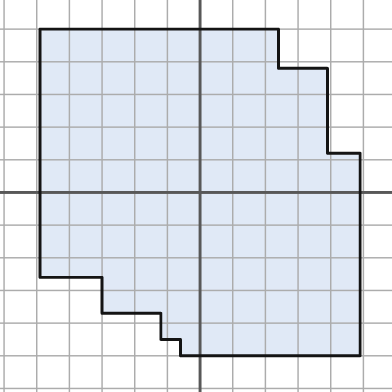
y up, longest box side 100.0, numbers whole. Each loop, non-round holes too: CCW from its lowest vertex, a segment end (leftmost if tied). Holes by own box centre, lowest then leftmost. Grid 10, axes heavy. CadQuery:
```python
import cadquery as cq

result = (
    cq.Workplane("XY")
    .moveTo(-6.0, -50.0)
    .lineTo(49.0, -50.0)
    .lineTo(49.0, 12.0)
    .lineTo(39.0, 12.0)
    .lineTo(39.0, 38.0)
    .lineTo(24.0, 38.0)
    .lineTo(24.0, 50.0)
    .lineTo(-49.0, 50.0)
    .lineTo(-49.0, -26.0)
    .lineTo(-30.0, -26.0)
    .lineTo(-30.0, -37.0)
    .lineTo(-12.0, -37.0)
    .lineTo(-12.0, -45.0)
    .lineTo(-6.0, -45.0)
    .close()
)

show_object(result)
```